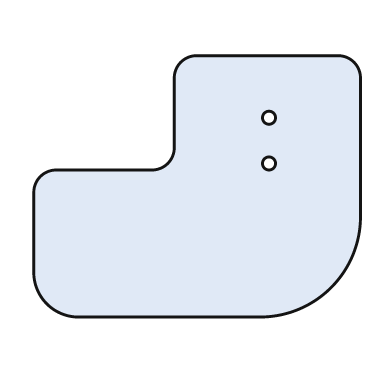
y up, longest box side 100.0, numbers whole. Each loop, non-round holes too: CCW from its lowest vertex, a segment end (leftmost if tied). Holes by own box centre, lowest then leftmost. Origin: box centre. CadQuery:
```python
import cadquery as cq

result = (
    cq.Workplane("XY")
    .moveTo(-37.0, -40.0)
    .lineTo(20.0, -40.0)
    .threePointArc((41.0, -31.0), (50.0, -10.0))
    .lineTo(50.0, 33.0)
    .threePointArc((48.0, 38.0), (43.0, 40.0))
    .lineTo(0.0, 40.0)
    .threePointArc((-5.0, 38.0), (-7.0, 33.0))
    .lineTo(-7.0, 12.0)
    .threePointArc((-9.0, 7.0), (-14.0, 5.0))
    .lineTo(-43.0, 5.0)
    .threePointArc((-48.0, 3.0), (-50.0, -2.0))
    .lineTo(-50.0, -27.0)
    .threePointArc((-46.0, -36.0), (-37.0, -40.0))
    .close()
    .moveTo(22.0, 7.0)
    .circle(2.0)
    .moveTo(22.0, 21.0)
    .circle(2.0)
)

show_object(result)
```